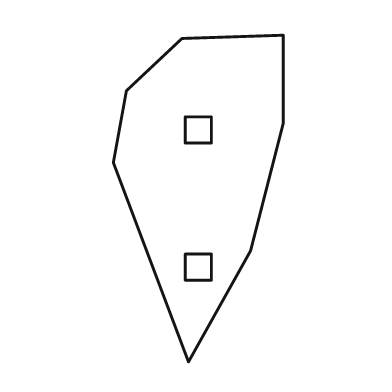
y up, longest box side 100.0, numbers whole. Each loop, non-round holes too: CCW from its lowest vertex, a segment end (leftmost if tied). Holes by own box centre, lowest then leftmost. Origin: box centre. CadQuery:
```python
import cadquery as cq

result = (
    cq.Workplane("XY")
    .moveTo(-3.0, -50.0)
    .lineTo(16.0, -16.0)
    .lineTo(26.0, 23.0)
    .lineTo(26.0, 50.0)
    .lineTo(-5.0, 49.0)
    .lineTo(-22.0, 33.0)
    .lineTo(-26.0, 11.0)
    .close()
    .moveTo(-4.0, -25.0)
    .lineTo(4.0, -25.0)
    .lineTo(4.0, -17.0)
    .lineTo(-4.0, -17.0)
    .close()
    .moveTo(-4.0, 17.0)
    .lineTo(4.0, 17.0)
    .lineTo(4.0, 25.0)
    .lineTo(-4.0, 25.0)
    .close()
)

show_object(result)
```